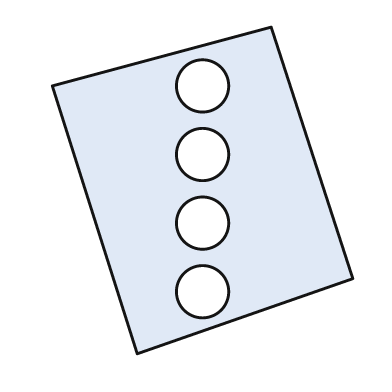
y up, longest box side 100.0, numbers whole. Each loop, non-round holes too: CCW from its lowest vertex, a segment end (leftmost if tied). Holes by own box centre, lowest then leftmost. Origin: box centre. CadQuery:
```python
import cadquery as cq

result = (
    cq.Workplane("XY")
    .moveTo(-20.0, -50.0)
    .lineTo(46.0, -27.0)
    .lineTo(21.0, 50.0)
    .lineTo(-46.0, 32.0)
    .close()
    .moveTo(0.0, -31.0)
    .circle(8.0)
    .moveTo(0.0, -10.0)
    .circle(8.0)
    .moveTo(0.0, 11.0)
    .circle(8.0)
    .moveTo(0.0, 32.0)
    .circle(8.0)
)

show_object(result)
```